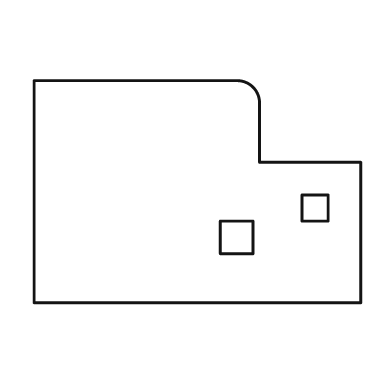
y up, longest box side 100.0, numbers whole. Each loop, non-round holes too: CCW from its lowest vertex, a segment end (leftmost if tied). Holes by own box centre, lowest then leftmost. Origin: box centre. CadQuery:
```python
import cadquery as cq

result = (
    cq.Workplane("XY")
    .moveTo(-50.0, -34.0)
    .lineTo(50.0, -34.0)
    .lineTo(50.0, 9.0)
    .lineTo(19.0, 9.0)
    .lineTo(19.0, 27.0)
    .threePointArc((17.0, 32.0), (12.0, 34.0))
    .lineTo(-50.0, 34.0)
    .close()
    .moveTo(7.0, -19.0)
    .lineTo(17.0, -19.0)
    .lineTo(17.0, -9.0)
    .lineTo(7.0, -9.0)
    .close()
    .moveTo(32.0, -9.0)
    .lineTo(40.0, -9.0)
    .lineTo(40.0, -1.0)
    .lineTo(32.0, -1.0)
    .close()
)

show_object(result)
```